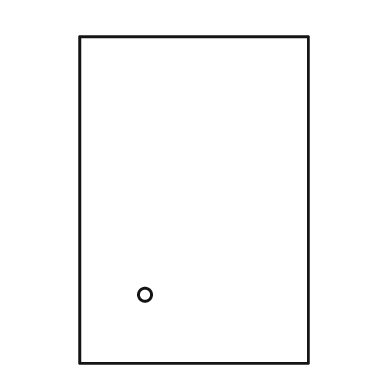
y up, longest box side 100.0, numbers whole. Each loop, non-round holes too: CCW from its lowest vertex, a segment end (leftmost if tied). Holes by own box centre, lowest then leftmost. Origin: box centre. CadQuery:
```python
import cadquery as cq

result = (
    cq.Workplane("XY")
    .moveTo(-35.0, -50.0)
    .lineTo(35.0, -50.0)
    .lineTo(35.0, 50.0)
    .lineTo(-35.0, 50.0)
    .close()
    .moveTo(-15.0, -29.0)
    .circle(2.0)
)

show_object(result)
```